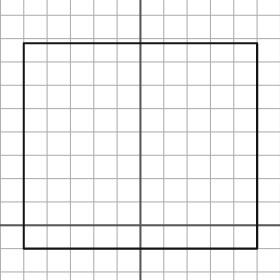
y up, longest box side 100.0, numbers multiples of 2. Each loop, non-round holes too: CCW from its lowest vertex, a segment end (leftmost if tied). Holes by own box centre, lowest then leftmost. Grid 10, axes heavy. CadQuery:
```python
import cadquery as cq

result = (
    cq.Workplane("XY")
    .moveTo(-50.0, -10.0)
    .lineTo(50.0, -10.0)
    .lineTo(50.0, 78.0)
    .lineTo(-50.0, 78.0)
    .close()
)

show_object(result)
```